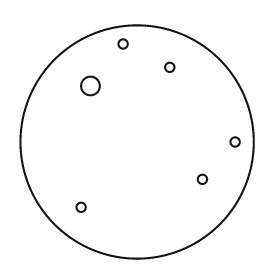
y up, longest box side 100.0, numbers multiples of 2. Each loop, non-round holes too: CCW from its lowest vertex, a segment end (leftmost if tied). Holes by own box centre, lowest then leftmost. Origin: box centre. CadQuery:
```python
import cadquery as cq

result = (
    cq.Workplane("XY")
    .moveTo(0.0, 0.0)
    .circle(50.0)
    .moveTo(-24.0, -28.0)
    .circle(2.0)
    .moveTo(28.0, -16.0)
    .circle(2.0)
    .moveTo(42.0, 0.0)
    .circle(2.0)
    .moveTo(-20.0, 24.0)
    .circle(4.0)
    .moveTo(14.0, 32.0)
    .circle(2.0)
    .moveTo(-6.0, 42.0)
    .circle(2.0)
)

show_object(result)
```